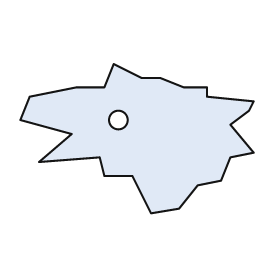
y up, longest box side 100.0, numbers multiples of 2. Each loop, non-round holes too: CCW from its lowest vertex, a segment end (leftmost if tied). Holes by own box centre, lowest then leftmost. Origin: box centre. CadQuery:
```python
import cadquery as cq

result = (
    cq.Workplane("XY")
    .moveTo(6.0, -32.0)
    .lineTo(18.0, -30.0)
    .lineTo(26.0, -20.0)
    .lineTo(36.0, -18.0)
    .lineTo(40.0, -8.0)
    .lineTo(50.0, -6.0)
    .lineTo(40.0, 6.0)
    .lineTo(48.0, 12.0)
    .lineTo(50.0, 16.0)
    .lineTo(30.0, 18.0)
    .lineTo(30.0, 22.0)
    .lineTo(20.0, 22.0)
    .lineTo(10.0, 26.0)
    .lineTo(2.0, 26.0)
    .lineTo(-10.0, 32.0)
    .lineTo(-14.0, 22.0)
    .lineTo(-26.0, 22.0)
    .lineTo(-46.0, 18.0)
    .lineTo(-50.0, 8.0)
    .lineTo(-28.0, 2.0)
    .lineTo(-42.0, -10.0)
    .lineTo(-16.0, -8.0)
    .lineTo(-14.0, -16.0)
    .lineTo(-2.0, -16.0)
    .close()
    .moveTo(-8.0, 8.0)
    .circle(4.0)
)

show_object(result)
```